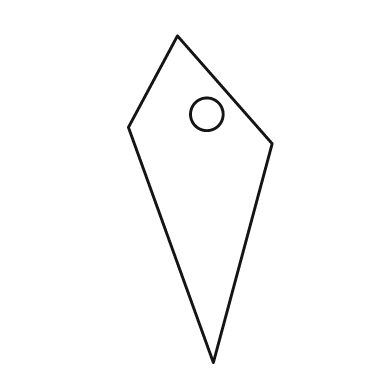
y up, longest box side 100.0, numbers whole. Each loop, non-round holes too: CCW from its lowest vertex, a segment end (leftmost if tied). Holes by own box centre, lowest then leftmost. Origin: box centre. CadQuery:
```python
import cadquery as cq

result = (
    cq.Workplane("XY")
    .moveTo(4.0, -50.0)
    .lineTo(22.0, 17.0)
    .lineTo(-7.0, 50.0)
    .lineTo(-22.0, 22.0)
    .close()
    .moveTo(2.0, 26.0)
    .circle(5.0)
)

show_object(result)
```